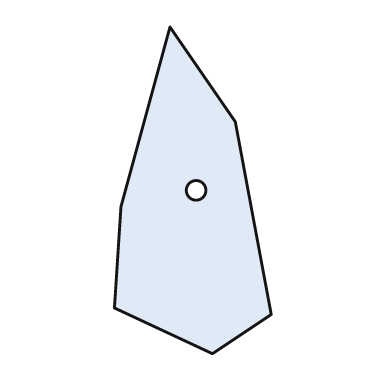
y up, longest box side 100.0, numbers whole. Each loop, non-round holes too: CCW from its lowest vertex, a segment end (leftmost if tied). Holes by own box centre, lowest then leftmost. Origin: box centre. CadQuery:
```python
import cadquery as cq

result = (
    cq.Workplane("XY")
    .moveTo(6.0, -50.0)
    .lineTo(24.0, -38.0)
    .lineTo(13.0, 21.0)
    .lineTo(-7.0, 50.0)
    .lineTo(-22.0, -5.0)
    .lineTo(-24.0, -36.0)
    .close()
    .moveTo(1.0, 0.0)
    .circle(3.0)
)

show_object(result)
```